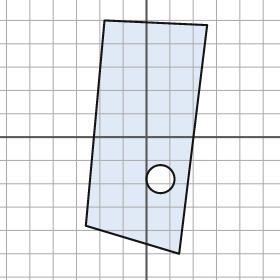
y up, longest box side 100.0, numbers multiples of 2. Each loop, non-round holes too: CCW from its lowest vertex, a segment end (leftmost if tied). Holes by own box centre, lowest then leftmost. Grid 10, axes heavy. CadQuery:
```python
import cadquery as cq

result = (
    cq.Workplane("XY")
    .moveTo(14.0, -50.0)
    .lineTo(26.0, 48.0)
    .lineTo(-18.0, 50.0)
    .lineTo(-26.0, -38.0)
    .close()
    .moveTo(6.0, -18.0)
    .circle(6.0)
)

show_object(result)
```